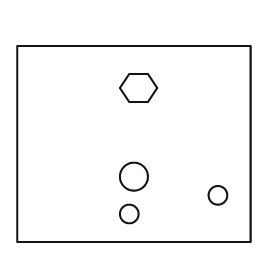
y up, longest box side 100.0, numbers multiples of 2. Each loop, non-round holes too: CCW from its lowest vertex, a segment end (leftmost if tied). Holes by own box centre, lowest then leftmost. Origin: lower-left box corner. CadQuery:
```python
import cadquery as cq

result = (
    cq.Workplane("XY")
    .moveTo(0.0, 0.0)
    .lineTo(100.0, 0.0)
    .lineTo(100.0, 84.0)
    .lineTo(0.0, 84.0)
    .close()
    .moveTo(48.0, 12.0)
    .circle(4.0)
    .moveTo(86.0, 20.0)
    .circle(4.0)
    .moveTo(50.0, 28.0)
    .circle(6.0)
    .moveTo(48.0, 60.0)
    .lineTo(56.0, 60.0)
    .lineTo(60.0, 66.0)
    .lineTo(56.0, 72.0)
    .lineTo(48.0, 72.0)
    .lineTo(44.0, 66.0)
    .close()
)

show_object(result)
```